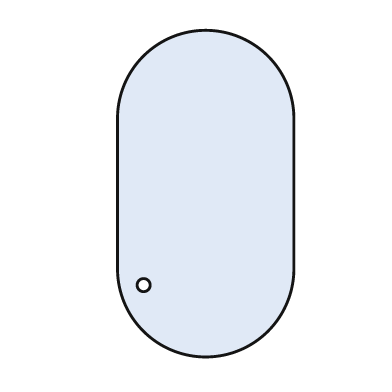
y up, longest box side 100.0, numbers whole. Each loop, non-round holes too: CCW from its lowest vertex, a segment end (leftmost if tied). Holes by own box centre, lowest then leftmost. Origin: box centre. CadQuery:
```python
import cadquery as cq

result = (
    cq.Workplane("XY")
    .moveTo(-27.0, -23.0)
    .threePointArc((0.0, -50.0), (27.0, -23.0))
    .lineTo(27.0, 23.0)
    .threePointArc((0.0, 50.0), (-27.0, 23.0))
    .close()
    .moveTo(-19.0, -28.0)
    .circle(2.0)
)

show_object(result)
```